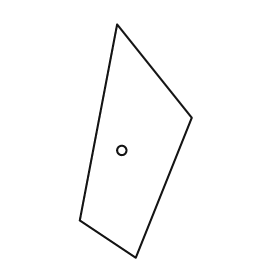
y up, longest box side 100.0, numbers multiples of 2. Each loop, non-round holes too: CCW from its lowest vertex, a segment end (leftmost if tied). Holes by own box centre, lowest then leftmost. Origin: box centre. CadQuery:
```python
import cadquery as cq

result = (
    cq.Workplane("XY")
    .moveTo(0.0, -50.0)
    .lineTo(24.0, 10.0)
    .lineTo(-8.0, 50.0)
    .lineTo(-24.0, -34.0)
    .close()
    .moveTo(-6.0, -4.0)
    .circle(2.0)
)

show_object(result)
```